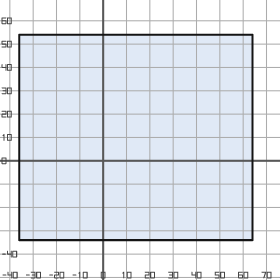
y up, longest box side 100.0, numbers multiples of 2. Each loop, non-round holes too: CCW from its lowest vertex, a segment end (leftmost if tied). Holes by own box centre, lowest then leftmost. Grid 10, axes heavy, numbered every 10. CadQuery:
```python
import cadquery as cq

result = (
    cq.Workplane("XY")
    .moveTo(-36.0, -34.0)
    .lineTo(64.0, -34.0)
    .lineTo(64.0, 54.0)
    .lineTo(-36.0, 54.0)
    .close()
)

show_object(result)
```